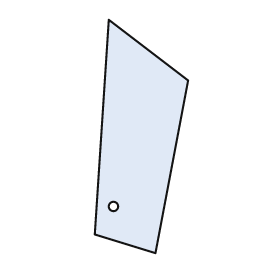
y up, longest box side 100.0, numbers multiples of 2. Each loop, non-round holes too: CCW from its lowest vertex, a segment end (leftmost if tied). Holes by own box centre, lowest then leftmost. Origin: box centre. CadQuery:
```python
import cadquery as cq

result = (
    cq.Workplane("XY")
    .moveTo(6.0, -50.0)
    .lineTo(20.0, 24.0)
    .lineTo(-14.0, 50.0)
    .lineTo(-20.0, -42.0)
    .close()
    .moveTo(-12.0, -30.0)
    .circle(2.0)
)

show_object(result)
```